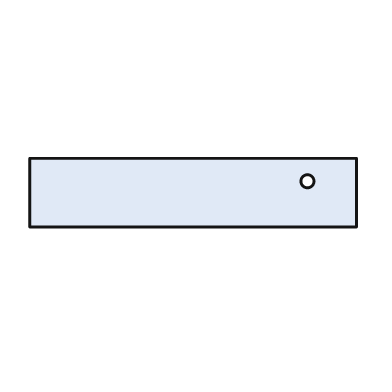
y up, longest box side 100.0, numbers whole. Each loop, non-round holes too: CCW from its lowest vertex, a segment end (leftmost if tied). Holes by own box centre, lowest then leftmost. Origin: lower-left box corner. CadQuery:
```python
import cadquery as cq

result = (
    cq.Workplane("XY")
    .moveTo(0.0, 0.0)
    .lineTo(100.0, 0.0)
    .lineTo(100.0, 21.0)
    .lineTo(0.0, 21.0)
    .close()
    .moveTo(85.0, 14.0)
    .circle(2.0)
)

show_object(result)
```